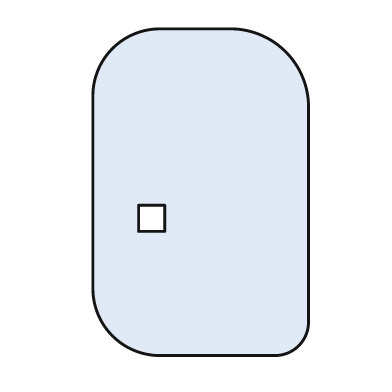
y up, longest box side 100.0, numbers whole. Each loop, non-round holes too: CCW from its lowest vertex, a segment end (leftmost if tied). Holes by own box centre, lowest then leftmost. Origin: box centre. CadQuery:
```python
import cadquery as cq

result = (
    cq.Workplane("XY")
    .moveTo(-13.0, -50.0)
    .lineTo(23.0, -50.0)
    .threePointArc((30.0, -47.0), (33.0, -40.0))
    .lineTo(33.0, 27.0)
    .threePointArc((26.0, 43.0), (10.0, 50.0))
    .lineTo(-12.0, 50.0)
    .threePointArc((-27.0, 44.0), (-33.0, 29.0))
    .lineTo(-33.0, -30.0)
    .threePointArc((-27.0, -44.0), (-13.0, -50.0))
    .close()
    .moveTo(-19.0, -12.0)
    .lineTo(-11.0, -12.0)
    .lineTo(-11.0, -4.0)
    .lineTo(-19.0, -4.0)
    .close()
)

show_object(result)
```